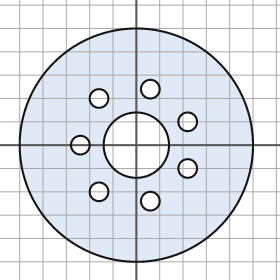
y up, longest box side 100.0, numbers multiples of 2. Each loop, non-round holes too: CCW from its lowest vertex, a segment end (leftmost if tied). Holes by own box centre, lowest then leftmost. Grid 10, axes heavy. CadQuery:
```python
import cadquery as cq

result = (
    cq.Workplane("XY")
    .moveTo(0.0, 0.0)
    .circle(50.0)
    .moveTo(6.0, -24.0)
    .circle(4.0)
    .moveTo(-16.0, -20.0)
    .circle(4.0)
    .moveTo(22.0, -10.0)
    .circle(4.0)
    .moveTo(-24.0, 0.0)
    .circle(4.0)
    .moveTo(0.0, 0.0)
    .circle(14.0)
    .moveTo(22.0, 10.0)
    .circle(4.0)
    .moveTo(-16.0, 20.0)
    .circle(4.0)
    .moveTo(6.0, 24.0)
    .circle(4.0)
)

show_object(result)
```